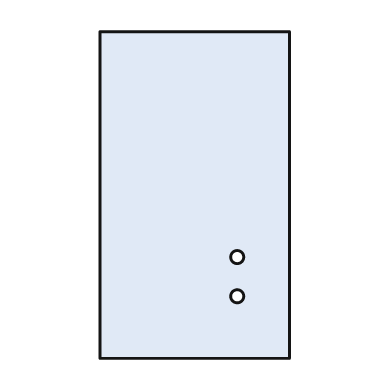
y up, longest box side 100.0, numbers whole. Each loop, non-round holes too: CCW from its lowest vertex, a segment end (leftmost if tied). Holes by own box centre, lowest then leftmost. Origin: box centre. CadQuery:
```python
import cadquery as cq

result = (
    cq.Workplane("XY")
    .moveTo(-29.0, -50.0)
    .lineTo(29.0, -50.0)
    .lineTo(29.0, 50.0)
    .lineTo(-29.0, 50.0)
    .close()
    .moveTo(13.0, -31.0)
    .circle(2.0)
    .moveTo(13.0, -19.0)
    .circle(2.0)
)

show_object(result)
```